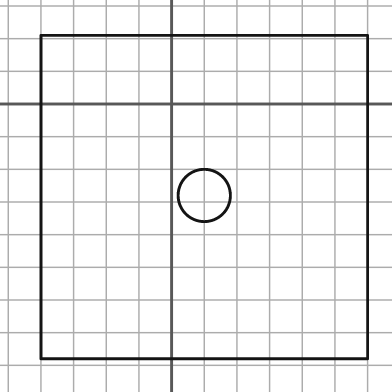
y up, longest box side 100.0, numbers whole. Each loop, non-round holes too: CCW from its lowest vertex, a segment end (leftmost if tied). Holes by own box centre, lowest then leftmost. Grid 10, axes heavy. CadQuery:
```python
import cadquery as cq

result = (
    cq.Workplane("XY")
    .moveTo(-40.0, -78.0)
    .lineTo(60.0, -78.0)
    .lineTo(60.0, 21.0)
    .lineTo(-40.0, 21.0)
    .close()
    .moveTo(10.0, -28.0)
    .circle(8.0)
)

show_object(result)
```